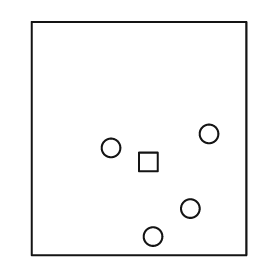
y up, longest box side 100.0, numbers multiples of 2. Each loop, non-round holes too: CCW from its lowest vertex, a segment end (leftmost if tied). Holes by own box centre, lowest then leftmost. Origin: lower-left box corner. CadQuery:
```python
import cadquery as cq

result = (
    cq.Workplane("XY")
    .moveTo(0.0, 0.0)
    .lineTo(92.0, 0.0)
    .lineTo(92.0, 100.0)
    .lineTo(0.0, 100.0)
    .close()
    .moveTo(52.0, 8.0)
    .circle(4.0)
    .moveTo(68.0, 20.0)
    .circle(4.0)
    .moveTo(46.0, 36.0)
    .lineTo(54.0, 36.0)
    .lineTo(54.0, 44.0)
    .lineTo(46.0, 44.0)
    .close()
    .moveTo(34.0, 46.0)
    .circle(4.0)
    .moveTo(76.0, 52.0)
    .circle(4.0)
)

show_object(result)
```